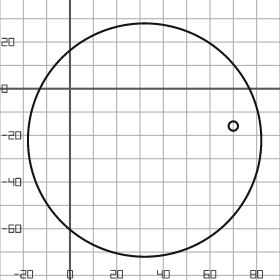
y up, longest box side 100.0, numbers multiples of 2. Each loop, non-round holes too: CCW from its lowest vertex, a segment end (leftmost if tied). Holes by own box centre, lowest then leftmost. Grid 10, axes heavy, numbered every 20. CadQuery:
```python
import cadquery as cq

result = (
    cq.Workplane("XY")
    .moveTo(32.0, -22.0)
    .circle(50.0)
    .moveTo(70.0, -16.0)
    .circle(2.0)
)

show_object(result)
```